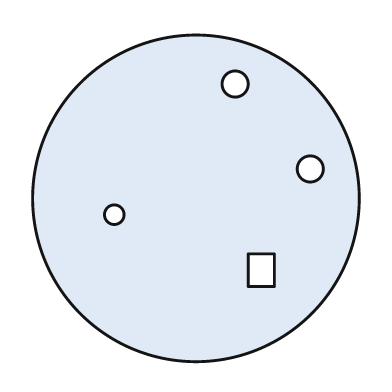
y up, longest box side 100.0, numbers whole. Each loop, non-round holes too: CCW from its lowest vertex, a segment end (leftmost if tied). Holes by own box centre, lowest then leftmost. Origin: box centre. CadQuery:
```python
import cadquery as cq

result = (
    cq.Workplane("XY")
    .moveTo(0.0, 0.0)
    .circle(50.0)
    .moveTo(16.0, -27.0)
    .lineTo(24.0, -27.0)
    .lineTo(24.0, -17.0)
    .lineTo(16.0, -17.0)
    .close()
    .moveTo(-25.0, -5.0)
    .circle(3.0)
    .moveTo(35.0, 9.0)
    .circle(4.0)
    .moveTo(12.0, 35.0)
    .circle(4.0)
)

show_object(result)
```